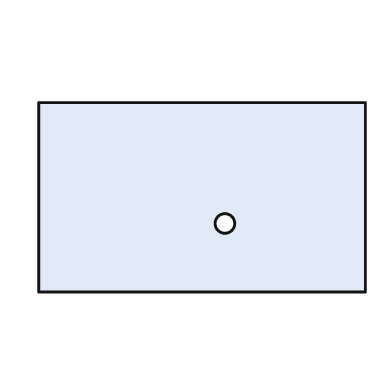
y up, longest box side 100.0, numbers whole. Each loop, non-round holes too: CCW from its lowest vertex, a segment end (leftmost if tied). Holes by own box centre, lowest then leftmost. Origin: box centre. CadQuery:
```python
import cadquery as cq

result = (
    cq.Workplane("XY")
    .moveTo(-50.0, -29.0)
    .lineTo(50.0, -29.0)
    .lineTo(50.0, 29.0)
    .lineTo(-50.0, 29.0)
    .close()
    .moveTo(7.0, -8.0)
    .circle(3.0)
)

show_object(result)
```